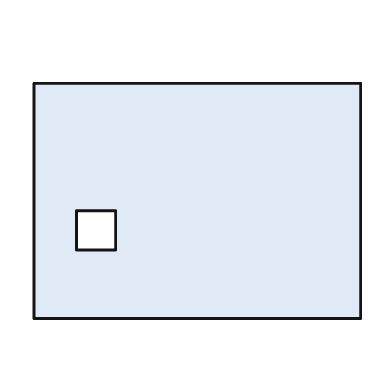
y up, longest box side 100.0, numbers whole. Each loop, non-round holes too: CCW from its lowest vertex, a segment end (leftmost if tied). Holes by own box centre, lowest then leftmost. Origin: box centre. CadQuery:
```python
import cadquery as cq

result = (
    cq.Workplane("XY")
    .moveTo(-50.0, -36.0)
    .lineTo(50.0, -36.0)
    .lineTo(50.0, 36.0)
    .lineTo(-50.0, 36.0)
    .close()
    .moveTo(-37.0, -15.0)
    .lineTo(-25.0, -15.0)
    .lineTo(-25.0, -3.0)
    .lineTo(-37.0, -3.0)
    .close()
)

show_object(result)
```